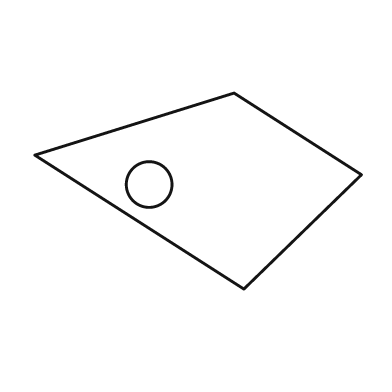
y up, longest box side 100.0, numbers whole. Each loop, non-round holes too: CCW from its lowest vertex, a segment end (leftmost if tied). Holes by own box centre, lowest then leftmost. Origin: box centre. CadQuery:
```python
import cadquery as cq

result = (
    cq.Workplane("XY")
    .moveTo(14.0, -30.0)
    .lineTo(50.0, 5.0)
    .lineTo(11.0, 30.0)
    .lineTo(-50.0, 11.0)
    .close()
    .moveTo(-15.0, 2.0)
    .circle(7.0)
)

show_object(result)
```